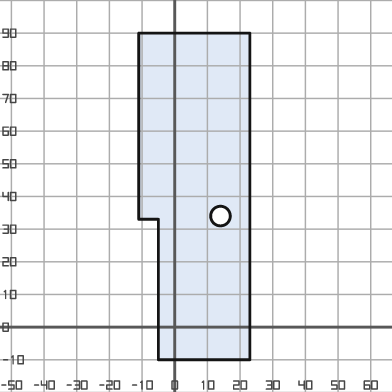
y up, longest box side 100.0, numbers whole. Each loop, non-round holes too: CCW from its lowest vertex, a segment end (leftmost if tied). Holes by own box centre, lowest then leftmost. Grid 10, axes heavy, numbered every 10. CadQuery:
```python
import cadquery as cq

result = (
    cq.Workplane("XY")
    .moveTo(-5.0, -10.0)
    .lineTo(23.0, -10.0)
    .lineTo(23.0, 90.0)
    .lineTo(-11.0, 90.0)
    .lineTo(-11.0, 33.0)
    .lineTo(-5.0, 33.0)
    .close()
    .moveTo(14.0, 34.0)
    .circle(3.0)
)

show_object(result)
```